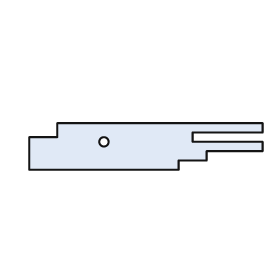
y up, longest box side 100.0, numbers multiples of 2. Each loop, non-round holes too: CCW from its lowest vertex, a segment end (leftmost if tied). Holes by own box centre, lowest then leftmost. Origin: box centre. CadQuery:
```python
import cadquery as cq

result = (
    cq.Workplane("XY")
    .moveTo(-50.0, -10.0)
    .lineTo(14.0, -10.0)
    .lineTo(14.0, -6.0)
    .lineTo(26.0, -6.0)
    .lineTo(26.0, -2.0)
    .lineTo(50.0, -2.0)
    .lineTo(50.0, 2.0)
    .lineTo(20.0, 2.0)
    .lineTo(20.0, 6.0)
    .lineTo(50.0, 6.0)
    .lineTo(50.0, 10.0)
    .lineTo(-38.0, 10.0)
    .lineTo(-38.0, 4.0)
    .lineTo(-50.0, 4.0)
    .close()
    .moveTo(-18.0, 2.0)
    .circle(2.0)
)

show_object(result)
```